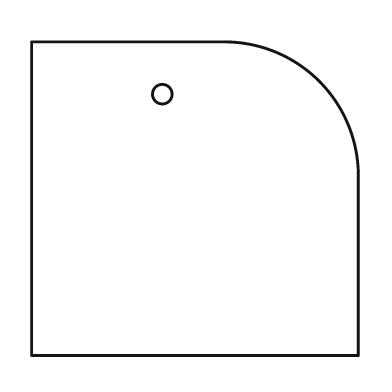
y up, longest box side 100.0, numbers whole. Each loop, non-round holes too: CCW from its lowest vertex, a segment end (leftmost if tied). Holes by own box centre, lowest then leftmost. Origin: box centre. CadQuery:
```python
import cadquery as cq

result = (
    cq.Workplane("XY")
    .moveTo(-50.0, -48.0)
    .lineTo(50.0, -48.0)
    .lineTo(50.0, 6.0)
    .threePointArc((38.0, 36.0), (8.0, 48.0))
    .lineTo(-50.0, 48.0)
    .close()
    .moveTo(-10.0, 32.0)
    .circle(3.0)
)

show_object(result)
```